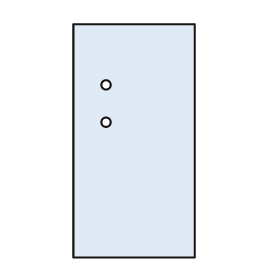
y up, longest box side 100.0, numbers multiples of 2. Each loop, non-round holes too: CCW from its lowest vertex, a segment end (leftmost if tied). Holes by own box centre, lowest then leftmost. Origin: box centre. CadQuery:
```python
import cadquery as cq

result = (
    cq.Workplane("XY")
    .moveTo(-26.0, -50.0)
    .lineTo(26.0, -50.0)
    .lineTo(26.0, 50.0)
    .lineTo(-26.0, 50.0)
    .close()
    .moveTo(-12.0, 8.0)
    .circle(2.0)
    .moveTo(-12.0, 24.0)
    .circle(2.0)
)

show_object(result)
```